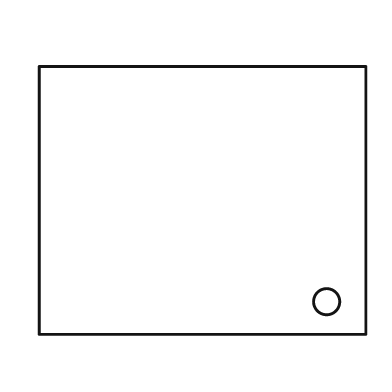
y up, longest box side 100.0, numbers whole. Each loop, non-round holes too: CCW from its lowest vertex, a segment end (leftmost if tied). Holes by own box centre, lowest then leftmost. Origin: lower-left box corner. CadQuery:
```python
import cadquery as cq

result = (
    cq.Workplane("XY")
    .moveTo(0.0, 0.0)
    .lineTo(100.0, 0.0)
    .lineTo(100.0, 82.0)
    .lineTo(0.0, 82.0)
    .close()
    .moveTo(88.0, 10.0)
    .circle(4.0)
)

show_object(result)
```